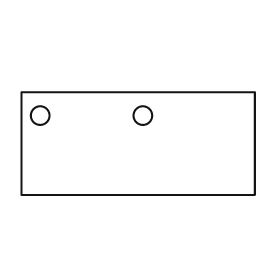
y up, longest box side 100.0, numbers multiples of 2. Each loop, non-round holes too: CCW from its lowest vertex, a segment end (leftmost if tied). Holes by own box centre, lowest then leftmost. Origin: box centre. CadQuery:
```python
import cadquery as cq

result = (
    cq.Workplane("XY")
    .moveTo(-50.0, -22.0)
    .lineTo(50.0, -22.0)
    .lineTo(50.0, 22.0)
    .lineTo(-50.0, 22.0)
    .close()
    .moveTo(-42.0, 12.0)
    .circle(4.0)
    .moveTo(2.0, 12.0)
    .circle(4.0)
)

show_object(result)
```